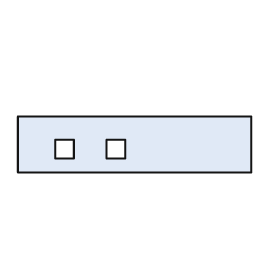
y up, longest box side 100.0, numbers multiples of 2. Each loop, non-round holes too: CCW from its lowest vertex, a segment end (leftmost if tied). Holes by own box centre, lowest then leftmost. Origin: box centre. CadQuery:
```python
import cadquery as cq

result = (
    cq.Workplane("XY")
    .moveTo(-50.0, -12.0)
    .lineTo(50.0, -12.0)
    .lineTo(50.0, 12.0)
    .lineTo(-50.0, 12.0)
    .close()
    .moveTo(-34.0, -6.0)
    .lineTo(-26.0, -6.0)
    .lineTo(-26.0, 2.0)
    .lineTo(-34.0, 2.0)
    .close()
    .moveTo(-12.0, -6.0)
    .lineTo(-4.0, -6.0)
    .lineTo(-4.0, 2.0)
    .lineTo(-12.0, 2.0)
    .close()
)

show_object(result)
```